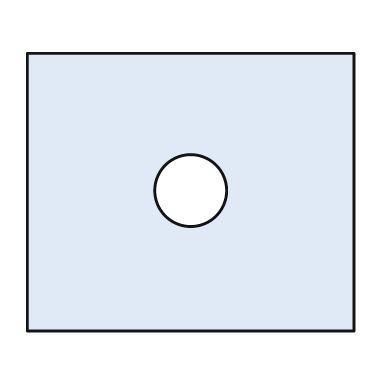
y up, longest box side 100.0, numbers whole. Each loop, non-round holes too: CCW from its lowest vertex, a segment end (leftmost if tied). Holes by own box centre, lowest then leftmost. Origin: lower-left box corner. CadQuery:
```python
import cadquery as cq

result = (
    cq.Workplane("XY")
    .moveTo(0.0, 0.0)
    .lineTo(100.0, 0.0)
    .lineTo(100.0, 85.0)
    .lineTo(0.0, 85.0)
    .close()
    .moveTo(50.0, 43.0)
    .circle(11.0)
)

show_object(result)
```